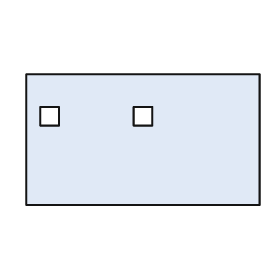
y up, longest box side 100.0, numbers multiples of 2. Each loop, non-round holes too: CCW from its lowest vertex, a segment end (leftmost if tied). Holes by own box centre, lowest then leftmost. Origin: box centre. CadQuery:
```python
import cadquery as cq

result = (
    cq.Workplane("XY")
    .moveTo(-50.0, -28.0)
    .lineTo(50.0, -28.0)
    .lineTo(50.0, 28.0)
    .lineTo(-50.0, 28.0)
    .close()
    .moveTo(-44.0, 6.0)
    .lineTo(-36.0, 6.0)
    .lineTo(-36.0, 14.0)
    .lineTo(-44.0, 14.0)
    .close()
    .moveTo(-4.0, 6.0)
    .lineTo(4.0, 6.0)
    .lineTo(4.0, 14.0)
    .lineTo(-4.0, 14.0)
    .close()
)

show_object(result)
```